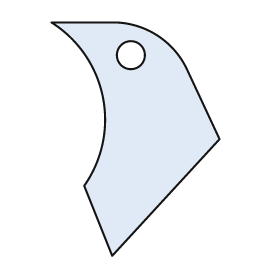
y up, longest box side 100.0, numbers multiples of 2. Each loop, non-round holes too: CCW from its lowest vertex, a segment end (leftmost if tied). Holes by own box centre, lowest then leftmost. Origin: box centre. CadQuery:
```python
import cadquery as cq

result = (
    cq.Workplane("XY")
    .moveTo(-10.0, -50.0)
    .lineTo(36.0, 0.0)
    .lineTo(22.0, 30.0)
    .threePointArc((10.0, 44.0), (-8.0, 50.0))
    .lineTo(-36.0, 50.0)
    .threePointArc((-14.0, 18.0), (-22.0, -20.0))
    .close()
    .moveTo(-2.0, 36.0)
    .circle(6.0)
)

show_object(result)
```